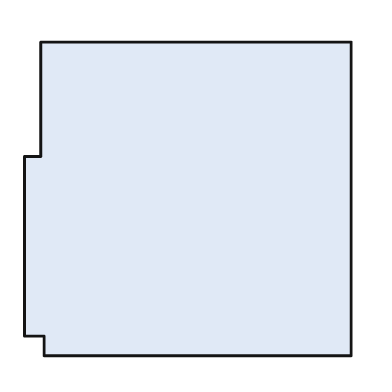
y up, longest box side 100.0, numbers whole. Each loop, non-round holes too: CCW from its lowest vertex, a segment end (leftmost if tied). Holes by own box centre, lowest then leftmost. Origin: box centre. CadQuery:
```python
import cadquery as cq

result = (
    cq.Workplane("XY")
    .moveTo(-44.0, -48.0)
    .lineTo(50.0, -48.0)
    .lineTo(50.0, 48.0)
    .lineTo(-45.0, 48.0)
    .lineTo(-45.0, 13.0)
    .lineTo(-50.0, 13.0)
    .lineTo(-50.0, -42.0)
    .lineTo(-44.0, -42.0)
    .close()
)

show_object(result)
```